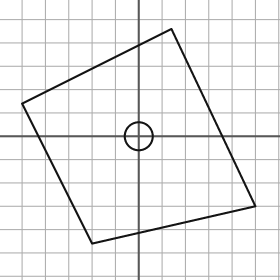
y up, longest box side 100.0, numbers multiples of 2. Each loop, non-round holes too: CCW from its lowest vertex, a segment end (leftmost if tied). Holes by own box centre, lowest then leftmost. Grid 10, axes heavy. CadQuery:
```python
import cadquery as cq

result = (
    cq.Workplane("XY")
    .moveTo(-20.0, -46.0)
    .lineTo(50.0, -30.0)
    .lineTo(14.0, 46.0)
    .lineTo(-50.0, 14.0)
    .close()
    .moveTo(0.0, 0.0)
    .circle(6.0)
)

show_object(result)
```